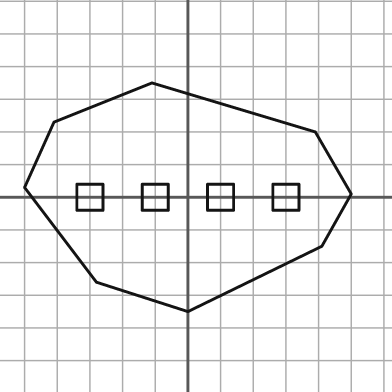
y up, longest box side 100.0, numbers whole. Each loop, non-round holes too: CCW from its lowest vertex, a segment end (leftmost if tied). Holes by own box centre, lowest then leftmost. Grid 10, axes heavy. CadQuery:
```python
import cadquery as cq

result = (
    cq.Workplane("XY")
    .moveTo(0.0, -35.0)
    .lineTo(41.0, -15.0)
    .lineTo(50.0, 1.0)
    .lineTo(39.0, 20.0)
    .lineTo(-11.0, 35.0)
    .lineTo(-41.0, 23.0)
    .lineTo(-50.0, 3.0)
    .lineTo(-28.0, -26.0)
    .close()
    .moveTo(-34.0, -4.0)
    .lineTo(-26.0, -4.0)
    .lineTo(-26.0, 4.0)
    .lineTo(-34.0, 4.0)
    .close()
    .moveTo(-14.0, -4.0)
    .lineTo(-6.0, -4.0)
    .lineTo(-6.0, 4.0)
    .lineTo(-14.0, 4.0)
    .close()
    .moveTo(6.0, -4.0)
    .lineTo(14.0, -4.0)
    .lineTo(14.0, 4.0)
    .lineTo(6.0, 4.0)
    .close()
    .moveTo(26.0, -4.0)
    .lineTo(34.0, -4.0)
    .lineTo(34.0, 4.0)
    .lineTo(26.0, 4.0)
    .close()
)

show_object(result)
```